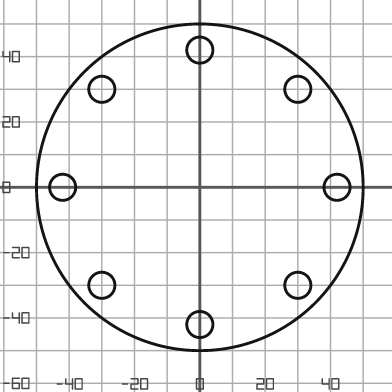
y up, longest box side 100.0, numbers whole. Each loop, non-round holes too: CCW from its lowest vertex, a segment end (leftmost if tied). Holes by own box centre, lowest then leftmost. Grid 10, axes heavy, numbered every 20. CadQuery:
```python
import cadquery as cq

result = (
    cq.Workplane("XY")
    .moveTo(0.0, 0.0)
    .circle(50.0)
    .moveTo(0.0, -42.0)
    .circle(4.0)
    .moveTo(-30.0, -30.0)
    .circle(4.0)
    .moveTo(30.0, -30.0)
    .circle(4.0)
    .moveTo(-42.0, 0.0)
    .circle(4.0)
    .moveTo(42.0, 0.0)
    .circle(4.0)
    .moveTo(-30.0, 30.0)
    .circle(4.0)
    .moveTo(30.0, 30.0)
    .circle(4.0)
    .moveTo(0.0, 42.0)
    .circle(4.0)
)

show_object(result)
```